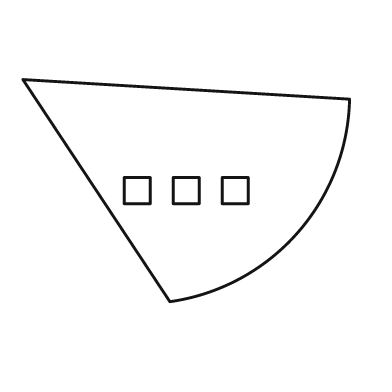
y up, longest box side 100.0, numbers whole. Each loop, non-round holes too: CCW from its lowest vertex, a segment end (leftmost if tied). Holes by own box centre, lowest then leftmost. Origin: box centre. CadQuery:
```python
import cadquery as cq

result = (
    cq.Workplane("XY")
    .moveTo(-5.0, -34.0)
    .threePointArc((34.0, -13.0), (50.0, 28.0))
    .lineTo(-50.0, 34.0)
    .close()
    .moveTo(-19.0, -4.0)
    .lineTo(-11.0, -4.0)
    .lineTo(-11.0, 4.0)
    .lineTo(-19.0, 4.0)
    .close()
    .moveTo(-4.0, -4.0)
    .lineTo(4.0, -4.0)
    .lineTo(4.0, 4.0)
    .lineTo(-4.0, 4.0)
    .close()
    .moveTo(11.0, -4.0)
    .lineTo(19.0, -4.0)
    .lineTo(19.0, 4.0)
    .lineTo(11.0, 4.0)
    .close()
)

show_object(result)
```